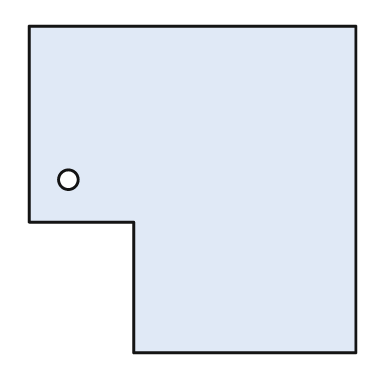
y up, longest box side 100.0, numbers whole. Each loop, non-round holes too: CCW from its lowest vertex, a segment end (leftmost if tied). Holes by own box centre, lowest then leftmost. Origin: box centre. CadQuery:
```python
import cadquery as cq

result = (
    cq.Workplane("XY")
    .moveTo(-18.0, -50.0)
    .lineTo(50.0, -50.0)
    .lineTo(50.0, 50.0)
    .lineTo(-50.0, 50.0)
    .lineTo(-50.0, -10.0)
    .lineTo(-18.0, -10.0)
    .close()
    .moveTo(-38.0, 3.0)
    .circle(3.0)
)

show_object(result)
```